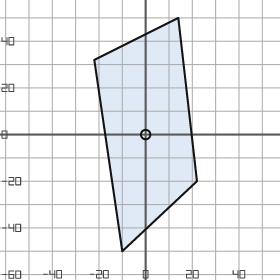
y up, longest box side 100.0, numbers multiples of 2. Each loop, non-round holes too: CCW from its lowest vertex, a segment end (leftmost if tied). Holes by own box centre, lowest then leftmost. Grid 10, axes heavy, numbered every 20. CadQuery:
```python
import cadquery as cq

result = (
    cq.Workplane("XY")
    .moveTo(-10.0, -50.0)
    .lineTo(22.0, -20.0)
    .lineTo(14.0, 50.0)
    .lineTo(-22.0, 32.0)
    .close()
    .moveTo(0.0, 0.0)
    .circle(2.0)
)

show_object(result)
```